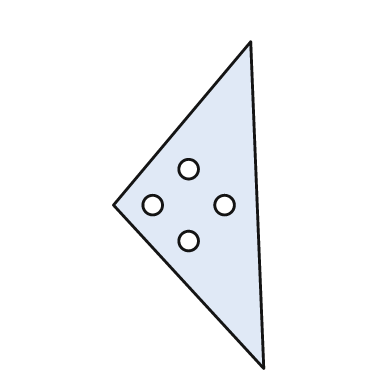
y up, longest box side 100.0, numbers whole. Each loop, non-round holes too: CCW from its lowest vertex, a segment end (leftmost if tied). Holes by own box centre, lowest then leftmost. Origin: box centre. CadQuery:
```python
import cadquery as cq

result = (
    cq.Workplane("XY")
    .moveTo(23.0, -50.0)
    .lineTo(19.0, 50.0)
    .lineTo(-23.0, 0.0)
    .close()
    .moveTo(0.0, -11.0)
    .circle(3.0)
    .moveTo(-11.0, 0.0)
    .circle(3.0)
    .moveTo(11.0, 0.0)
    .circle(3.0)
    .moveTo(0.0, 11.0)
    .circle(3.0)
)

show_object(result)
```